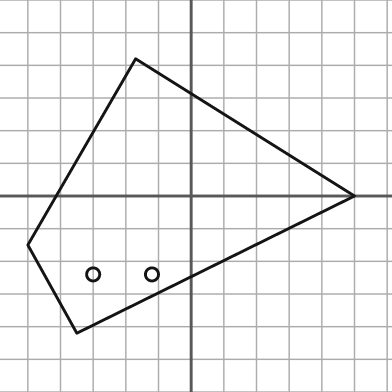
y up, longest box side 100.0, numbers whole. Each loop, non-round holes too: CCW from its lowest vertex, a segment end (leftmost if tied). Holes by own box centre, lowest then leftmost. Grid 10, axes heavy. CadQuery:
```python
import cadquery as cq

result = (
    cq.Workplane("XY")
    .moveTo(-35.0, -42.0)
    .lineTo(50.0, 0.0)
    .lineTo(-17.0, 42.0)
    .lineTo(-50.0, -15.0)
    .close()
    .moveTo(-30.0, -24.0)
    .circle(2.0)
    .moveTo(-12.0, -24.0)
    .circle(2.0)
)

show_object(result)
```